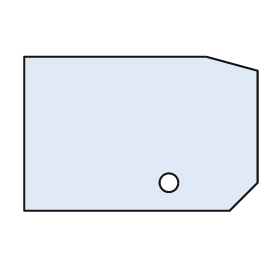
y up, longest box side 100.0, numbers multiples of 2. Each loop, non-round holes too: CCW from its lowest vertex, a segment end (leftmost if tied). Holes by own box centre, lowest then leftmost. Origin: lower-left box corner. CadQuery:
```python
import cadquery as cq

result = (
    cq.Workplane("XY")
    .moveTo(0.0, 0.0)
    .lineTo(88.0, 0.0)
    .lineTo(100.0, 12.0)
    .lineTo(100.0, 60.0)
    .lineTo(78.0, 66.0)
    .lineTo(0.0, 66.0)
    .close()
    .moveTo(62.0, 12.0)
    .circle(4.0)
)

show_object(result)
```